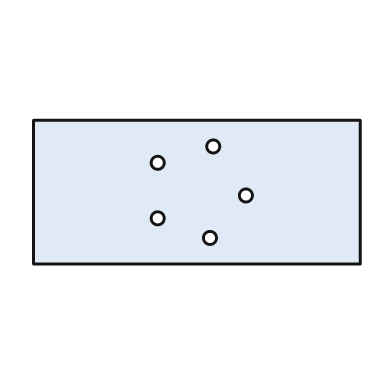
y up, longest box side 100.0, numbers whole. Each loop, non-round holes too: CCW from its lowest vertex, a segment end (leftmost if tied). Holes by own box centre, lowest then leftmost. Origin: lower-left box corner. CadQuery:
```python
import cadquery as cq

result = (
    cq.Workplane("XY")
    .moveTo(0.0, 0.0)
    .lineTo(100.0, 0.0)
    .lineTo(100.0, 44.0)
    .lineTo(0.0, 44.0)
    .close()
    .moveTo(54.0, 8.0)
    .circle(2.0)
    .moveTo(38.0, 14.0)
    .circle(2.0)
    .moveTo(65.0, 21.0)
    .circle(2.0)
    .moveTo(38.0, 31.0)
    .circle(2.0)
    .moveTo(55.0, 36.0)
    .circle(2.0)
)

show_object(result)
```